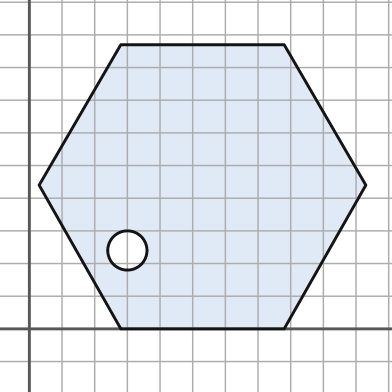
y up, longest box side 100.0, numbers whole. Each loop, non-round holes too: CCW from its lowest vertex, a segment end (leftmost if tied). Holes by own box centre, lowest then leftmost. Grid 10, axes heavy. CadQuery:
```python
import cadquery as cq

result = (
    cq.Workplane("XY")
    .moveTo(28.0, 0.0)
    .lineTo(78.0, 0.0)
    .lineTo(103.0, 44.0)
    .lineTo(78.0, 87.0)
    .lineTo(28.0, 87.0)
    .lineTo(3.0, 44.0)
    .close()
    .moveTo(30.0, 24.0)
    .circle(6.0)
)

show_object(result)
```